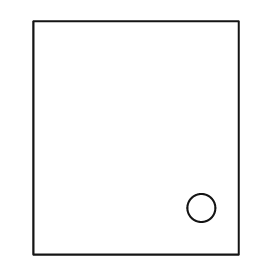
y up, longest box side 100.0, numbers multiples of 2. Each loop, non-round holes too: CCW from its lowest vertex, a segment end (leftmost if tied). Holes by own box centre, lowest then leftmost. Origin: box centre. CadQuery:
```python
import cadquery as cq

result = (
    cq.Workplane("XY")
    .moveTo(-44.0, -50.0)
    .lineTo(44.0, -50.0)
    .lineTo(44.0, 50.0)
    .lineTo(-44.0, 50.0)
    .close()
    .moveTo(28.0, -30.0)
    .circle(6.0)
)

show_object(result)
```